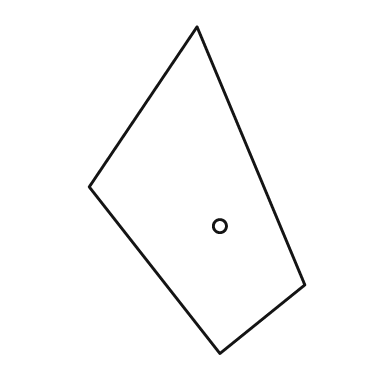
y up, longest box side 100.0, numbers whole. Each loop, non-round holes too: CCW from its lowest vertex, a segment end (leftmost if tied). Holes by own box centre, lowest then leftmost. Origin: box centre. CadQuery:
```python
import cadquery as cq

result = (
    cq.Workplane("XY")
    .moveTo(7.0, -50.0)
    .lineTo(33.0, -29.0)
    .lineTo(0.0, 50.0)
    .lineTo(-33.0, 1.0)
    .close()
    .moveTo(7.0, -11.0)
    .circle(2.0)
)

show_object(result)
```